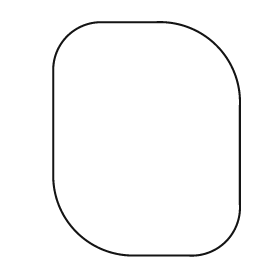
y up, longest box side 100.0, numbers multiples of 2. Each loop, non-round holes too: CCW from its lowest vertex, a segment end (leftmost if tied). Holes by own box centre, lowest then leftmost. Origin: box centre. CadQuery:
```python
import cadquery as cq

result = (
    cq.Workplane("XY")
    .moveTo(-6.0, -50.0)
    .lineTo(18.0, -50.0)
    .threePointArc((34.0, -44.0), (40.0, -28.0))
    .lineTo(40.0, 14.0)
    .threePointArc((30.0, 40.0), (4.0, 50.0))
    .lineTo(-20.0, 50.0)
    .threePointArc((-34.0, 44.0), (-40.0, 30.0))
    .lineTo(-40.0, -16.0)
    .threePointArc((-30.0, -40.0), (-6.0, -50.0))
    .close()
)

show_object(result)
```